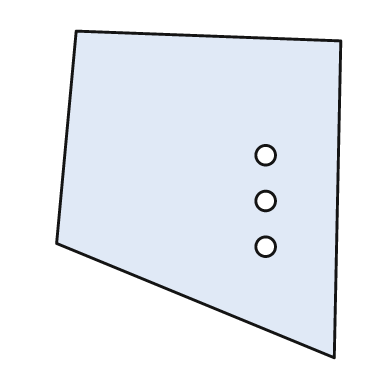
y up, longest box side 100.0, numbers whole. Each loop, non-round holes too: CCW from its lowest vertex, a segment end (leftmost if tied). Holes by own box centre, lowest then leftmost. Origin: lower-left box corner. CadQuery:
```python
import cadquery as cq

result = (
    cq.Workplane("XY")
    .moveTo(85.0, 0.0)
    .lineTo(87.0, 97.0)
    .lineTo(6.0, 100.0)
    .lineTo(0.0, 35.0)
    .close()
    .moveTo(64.0, 34.0)
    .circle(3.0)
    .moveTo(64.0, 48.0)
    .circle(3.0)
    .moveTo(64.0, 62.0)
    .circle(3.0)
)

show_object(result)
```